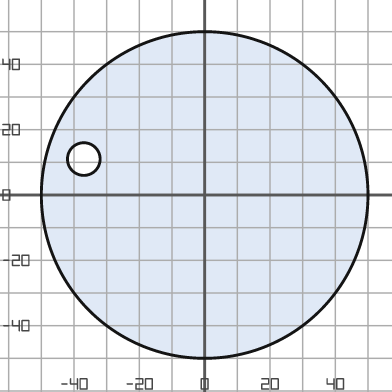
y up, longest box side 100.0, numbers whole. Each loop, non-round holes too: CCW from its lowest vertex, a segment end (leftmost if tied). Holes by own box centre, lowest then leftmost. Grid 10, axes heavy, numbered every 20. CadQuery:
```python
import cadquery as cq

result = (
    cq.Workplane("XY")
    .moveTo(0.0, 0.0)
    .circle(50.0)
    .moveTo(-37.0, 11.0)
    .circle(5.0)
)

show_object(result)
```